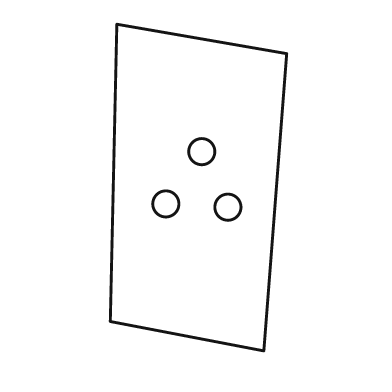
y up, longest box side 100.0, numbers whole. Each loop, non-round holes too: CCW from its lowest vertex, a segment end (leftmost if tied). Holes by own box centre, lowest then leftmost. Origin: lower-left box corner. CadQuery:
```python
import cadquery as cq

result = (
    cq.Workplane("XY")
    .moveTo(47.0, 0.0)
    .lineTo(54.0, 91.0)
    .lineTo(2.0, 100.0)
    .lineTo(0.0, 9.0)
    .close()
    .moveTo(36.0, 44.0)
    .circle(4.0)
    .moveTo(17.0, 45.0)
    .circle(4.0)
    .moveTo(28.0, 61.0)
    .circle(4.0)
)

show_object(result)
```